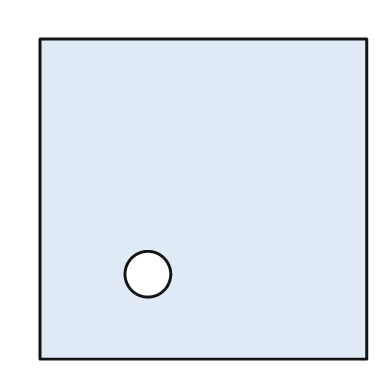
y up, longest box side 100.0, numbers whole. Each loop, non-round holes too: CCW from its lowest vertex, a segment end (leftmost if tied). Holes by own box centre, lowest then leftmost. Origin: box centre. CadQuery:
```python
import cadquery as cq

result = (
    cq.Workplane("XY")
    .moveTo(-50.0, -49.0)
    .lineTo(50.0, -49.0)
    .lineTo(50.0, 49.0)
    .lineTo(-50.0, 49.0)
    .close()
    .moveTo(-17.0, -23.0)
    .circle(7.0)
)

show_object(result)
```